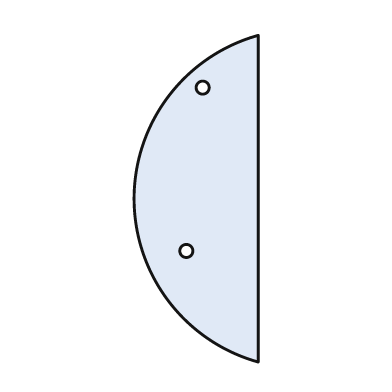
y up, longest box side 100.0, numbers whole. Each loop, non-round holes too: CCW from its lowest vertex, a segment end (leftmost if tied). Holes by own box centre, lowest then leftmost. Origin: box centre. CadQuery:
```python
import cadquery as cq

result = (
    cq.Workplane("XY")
    .moveTo(19.0, -50.0)
    .lineTo(19.0, 50.0)
    .threePointArc((-19.0, 0.0), (19.0, -50.0))
    .close()
    .moveTo(-3.0, -16.0)
    .circle(2.0)
    .moveTo(2.0, 34.0)
    .circle(2.0)
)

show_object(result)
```